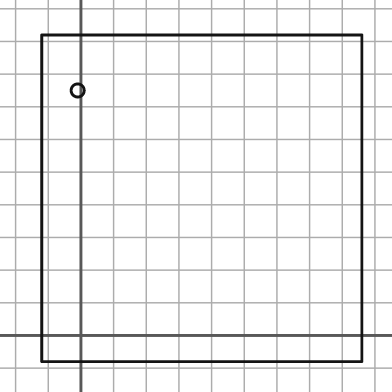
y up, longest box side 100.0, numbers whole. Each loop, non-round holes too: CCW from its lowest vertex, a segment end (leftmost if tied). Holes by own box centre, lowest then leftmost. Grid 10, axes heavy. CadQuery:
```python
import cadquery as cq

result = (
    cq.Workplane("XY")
    .moveTo(-12.0, -8.0)
    .lineTo(86.0, -8.0)
    .lineTo(86.0, 92.0)
    .lineTo(-12.0, 92.0)
    .close()
    .moveTo(-1.0, 75.0)
    .circle(2.0)
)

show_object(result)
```